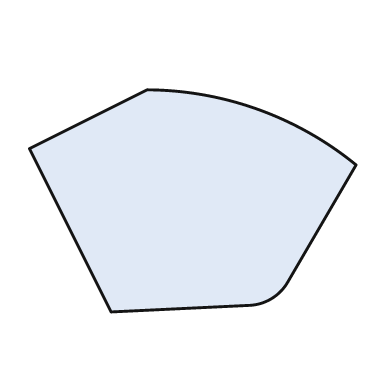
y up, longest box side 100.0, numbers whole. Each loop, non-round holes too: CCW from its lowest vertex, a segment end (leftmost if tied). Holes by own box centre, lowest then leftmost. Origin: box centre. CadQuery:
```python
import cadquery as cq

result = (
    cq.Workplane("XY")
    .moveTo(-25.0, -34.0)
    .lineTo(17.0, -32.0)
    .threePointArc((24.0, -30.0), (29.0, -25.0))
    .lineTo(50.0, 11.0)
    .threePointArc((20.0, 28.0), (-14.0, 34.0))
    .lineTo(-50.0, 16.0)
    .close()
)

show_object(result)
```